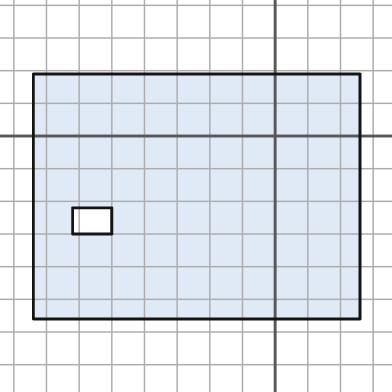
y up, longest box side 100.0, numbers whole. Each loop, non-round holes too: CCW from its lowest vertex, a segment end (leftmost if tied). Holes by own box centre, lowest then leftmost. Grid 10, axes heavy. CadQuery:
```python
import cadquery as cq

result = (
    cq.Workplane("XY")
    .moveTo(-74.0, -56.0)
    .lineTo(26.0, -56.0)
    .lineTo(26.0, 19.0)
    .lineTo(-74.0, 19.0)
    .close()
    .moveTo(-62.0, -30.0)
    .lineTo(-50.0, -30.0)
    .lineTo(-50.0, -22.0)
    .lineTo(-62.0, -22.0)
    .close()
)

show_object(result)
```